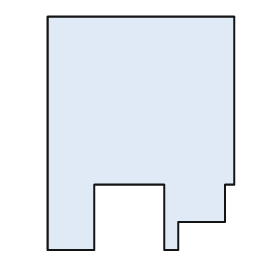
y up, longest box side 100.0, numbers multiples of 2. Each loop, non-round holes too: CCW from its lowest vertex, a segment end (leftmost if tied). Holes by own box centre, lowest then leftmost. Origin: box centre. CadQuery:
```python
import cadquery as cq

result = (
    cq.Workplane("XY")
    .moveTo(-40.0, -50.0)
    .lineTo(-20.0, -50.0)
    .lineTo(-20.0, -22.0)
    .lineTo(10.0, -22.0)
    .lineTo(10.0, -50.0)
    .lineTo(16.0, -50.0)
    .lineTo(16.0, -38.0)
    .lineTo(36.0, -38.0)
    .lineTo(36.0, -22.0)
    .lineTo(40.0, -22.0)
    .lineTo(40.0, 50.0)
    .lineTo(-40.0, 50.0)
    .close()
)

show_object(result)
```